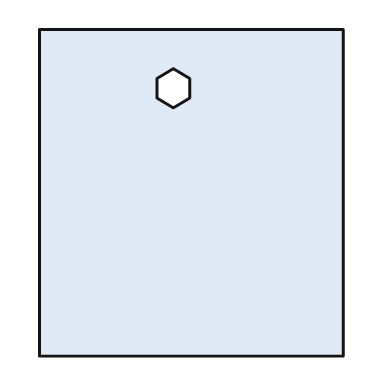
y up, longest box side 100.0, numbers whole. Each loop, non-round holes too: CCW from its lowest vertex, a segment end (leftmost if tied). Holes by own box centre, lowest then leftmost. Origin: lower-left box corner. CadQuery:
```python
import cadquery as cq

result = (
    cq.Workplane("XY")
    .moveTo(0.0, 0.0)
    .lineTo(93.0, 0.0)
    .lineTo(93.0, 100.0)
    .lineTo(0.0, 100.0)
    .close()
    .moveTo(41.0, 76.0)
    .lineTo(46.0, 79.0)
    .lineTo(46.0, 85.0)
    .lineTo(41.0, 88.0)
    .lineTo(36.0, 85.0)
    .lineTo(36.0, 79.0)
    .close()
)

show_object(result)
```